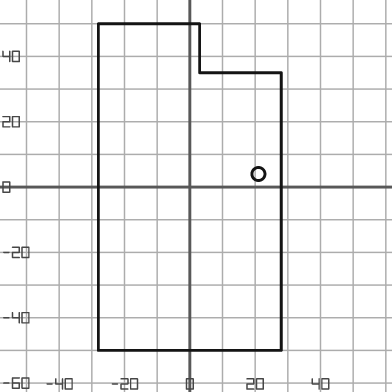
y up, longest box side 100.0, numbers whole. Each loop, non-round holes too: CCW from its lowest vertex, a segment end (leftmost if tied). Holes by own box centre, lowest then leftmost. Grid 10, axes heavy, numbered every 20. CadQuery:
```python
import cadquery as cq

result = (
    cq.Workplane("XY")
    .moveTo(-28.0, -50.0)
    .lineTo(28.0, -50.0)
    .lineTo(28.0, 35.0)
    .lineTo(3.0, 35.0)
    .lineTo(3.0, 50.0)
    .lineTo(-28.0, 50.0)
    .close()
    .moveTo(21.0, 4.0)
    .circle(2.0)
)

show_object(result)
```